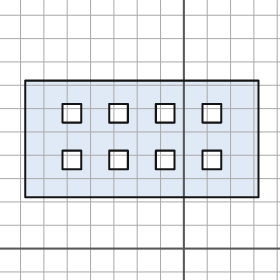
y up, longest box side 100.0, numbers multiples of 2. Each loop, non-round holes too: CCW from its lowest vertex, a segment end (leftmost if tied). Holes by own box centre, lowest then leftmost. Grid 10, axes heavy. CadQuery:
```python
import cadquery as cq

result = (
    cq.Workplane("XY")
    .moveTo(-68.0, 22.0)
    .lineTo(32.0, 22.0)
    .lineTo(32.0, 72.0)
    .lineTo(-68.0, 72.0)
    .close()
    .moveTo(-52.0, 34.0)
    .lineTo(-44.0, 34.0)
    .lineTo(-44.0, 42.0)
    .lineTo(-52.0, 42.0)
    .close()
    .moveTo(-32.0, 34.0)
    .lineTo(-24.0, 34.0)
    .lineTo(-24.0, 42.0)
    .lineTo(-32.0, 42.0)
    .close()
    .moveTo(-12.0, 34.0)
    .lineTo(-4.0, 34.0)
    .lineTo(-4.0, 42.0)
    .lineTo(-12.0, 42.0)
    .close()
    .moveTo(8.0, 34.0)
    .lineTo(16.0, 34.0)
    .lineTo(16.0, 42.0)
    .lineTo(8.0, 42.0)
    .close()
    .moveTo(-52.0, 54.0)
    .lineTo(-44.0, 54.0)
    .lineTo(-44.0, 62.0)
    .lineTo(-52.0, 62.0)
    .close()
    .moveTo(-32.0, 54.0)
    .lineTo(-24.0, 54.0)
    .lineTo(-24.0, 62.0)
    .lineTo(-32.0, 62.0)
    .close()
    .moveTo(-12.0, 54.0)
    .lineTo(-4.0, 54.0)
    .lineTo(-4.0, 62.0)
    .lineTo(-12.0, 62.0)
    .close()
    .moveTo(8.0, 54.0)
    .lineTo(16.0, 54.0)
    .lineTo(16.0, 62.0)
    .lineTo(8.0, 62.0)
    .close()
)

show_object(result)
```